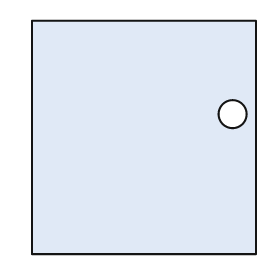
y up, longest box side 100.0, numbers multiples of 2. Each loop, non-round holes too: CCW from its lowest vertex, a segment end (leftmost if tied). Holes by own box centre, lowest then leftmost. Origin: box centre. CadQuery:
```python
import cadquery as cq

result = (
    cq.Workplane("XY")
    .moveTo(-48.0, -50.0)
    .lineTo(48.0, -50.0)
    .lineTo(48.0, 50.0)
    .lineTo(-48.0, 50.0)
    .close()
    .moveTo(38.0, 10.0)
    .circle(6.0)
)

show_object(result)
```